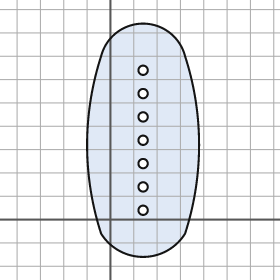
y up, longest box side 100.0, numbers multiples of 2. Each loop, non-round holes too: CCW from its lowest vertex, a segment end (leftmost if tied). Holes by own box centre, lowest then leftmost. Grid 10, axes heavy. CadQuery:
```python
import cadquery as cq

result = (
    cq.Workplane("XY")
    .moveTo(-4.0, -6.0)
    .threePointArc((14.0, -16.0), (32.0, -6.0))
    .threePointArc((38.0, 32.0), (32.0, 70.0))
    .threePointArc((14.0, 84.0), (-4.0, 70.0))
    .threePointArc((-10.0, 32.0), (-4.0, -6.0))
    .close()
    .moveTo(14.0, 4.0)
    .circle(2.0)
    .moveTo(14.0, 14.0)
    .circle(2.0)
    .moveTo(14.0, 24.0)
    .circle(2.0)
    .moveTo(14.0, 34.0)
    .circle(2.0)
    .moveTo(14.0, 44.0)
    .circle(2.0)
    .moveTo(14.0, 54.0)
    .circle(2.0)
    .moveTo(14.0, 64.0)
    .circle(2.0)
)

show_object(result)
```